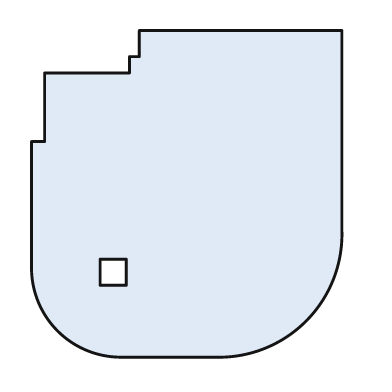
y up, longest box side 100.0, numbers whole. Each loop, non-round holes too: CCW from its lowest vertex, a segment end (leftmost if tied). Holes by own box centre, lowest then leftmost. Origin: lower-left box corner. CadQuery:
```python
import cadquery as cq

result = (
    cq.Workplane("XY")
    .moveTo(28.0, 0.0)
    .lineTo(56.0, 0.0)
    .threePointArc((84.0, 11.0), (95.0, 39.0))
    .lineTo(95.0, 100.0)
    .lineTo(33.0, 100.0)
    .lineTo(33.0, 92.0)
    .lineTo(30.0, 92.0)
    .lineTo(30.0, 87.0)
    .lineTo(4.0, 87.0)
    .lineTo(4.0, 66.0)
    .lineTo(0.0, 66.0)
    .lineTo(0.0, 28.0)
    .threePointArc((8.0, 8.0), (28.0, 0.0))
    .close()
    .moveTo(21.0, 22.0)
    .lineTo(29.0, 22.0)
    .lineTo(29.0, 30.0)
    .lineTo(21.0, 30.0)
    .close()
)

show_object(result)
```